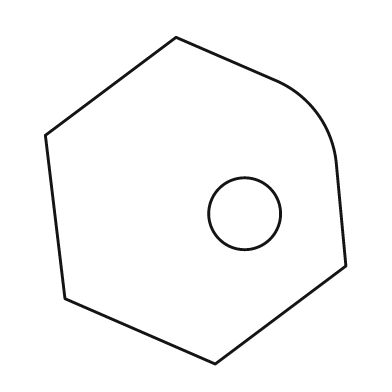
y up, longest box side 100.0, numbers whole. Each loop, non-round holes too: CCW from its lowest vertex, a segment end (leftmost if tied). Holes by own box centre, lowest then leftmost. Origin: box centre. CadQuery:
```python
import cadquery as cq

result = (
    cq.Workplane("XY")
    .moveTo(6.0, -50.0)
    .lineTo(46.0, -20.0)
    .lineTo(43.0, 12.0)
    .threePointArc((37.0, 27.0), (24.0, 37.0))
    .lineTo(-6.0, 50.0)
    .lineTo(-46.0, 20.0)
    .lineTo(-40.0, -30.0)
    .close()
    .moveTo(15.0, -4.0)
    .circle(11.0)
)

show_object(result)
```